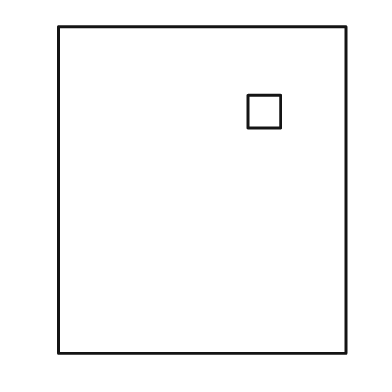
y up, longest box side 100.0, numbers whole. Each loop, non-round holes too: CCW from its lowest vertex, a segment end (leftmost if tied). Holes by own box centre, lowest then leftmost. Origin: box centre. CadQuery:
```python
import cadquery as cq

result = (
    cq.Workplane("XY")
    .moveTo(-44.0, -50.0)
    .lineTo(44.0, -50.0)
    .lineTo(44.0, 50.0)
    .lineTo(-44.0, 50.0)
    .close()
    .moveTo(14.0, 19.0)
    .lineTo(24.0, 19.0)
    .lineTo(24.0, 29.0)
    .lineTo(14.0, 29.0)
    .close()
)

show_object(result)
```